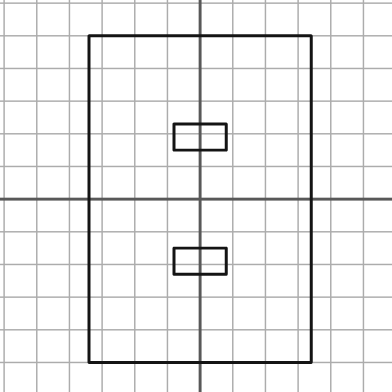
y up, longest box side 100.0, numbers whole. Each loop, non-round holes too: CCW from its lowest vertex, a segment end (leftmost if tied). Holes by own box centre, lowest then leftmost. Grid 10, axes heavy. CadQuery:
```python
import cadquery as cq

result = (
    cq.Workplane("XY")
    .moveTo(-34.0, -50.0)
    .lineTo(34.0, -50.0)
    .lineTo(34.0, 50.0)
    .lineTo(-34.0, 50.0)
    .close()
    .moveTo(-8.0, -23.0)
    .lineTo(8.0, -23.0)
    .lineTo(8.0, -15.0)
    .lineTo(-8.0, -15.0)
    .close()
    .moveTo(-8.0, 15.0)
    .lineTo(8.0, 15.0)
    .lineTo(8.0, 23.0)
    .lineTo(-8.0, 23.0)
    .close()
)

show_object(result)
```